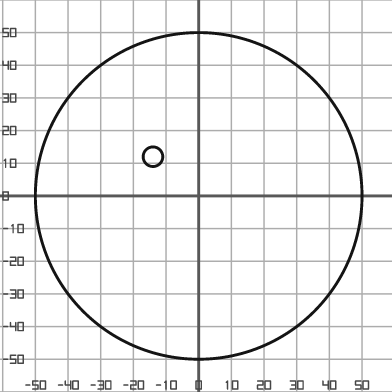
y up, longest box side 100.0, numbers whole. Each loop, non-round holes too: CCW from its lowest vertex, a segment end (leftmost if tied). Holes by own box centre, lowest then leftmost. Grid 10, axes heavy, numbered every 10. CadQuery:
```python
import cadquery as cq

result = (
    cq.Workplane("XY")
    .moveTo(0.0, 0.0)
    .circle(50.0)
    .moveTo(-14.0, 12.0)
    .circle(3.0)
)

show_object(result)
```